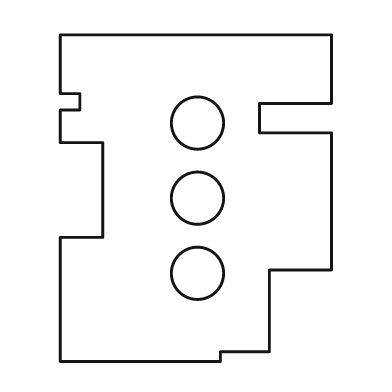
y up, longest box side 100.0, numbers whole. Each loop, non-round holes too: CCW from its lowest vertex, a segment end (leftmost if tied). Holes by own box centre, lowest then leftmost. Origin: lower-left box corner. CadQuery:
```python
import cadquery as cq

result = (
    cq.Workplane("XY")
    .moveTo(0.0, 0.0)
    .lineTo(49.0, 0.0)
    .lineTo(49.0, 3.0)
    .lineTo(64.0, 3.0)
    .lineTo(64.0, 28.0)
    .lineTo(83.0, 28.0)
    .lineTo(83.0, 70.0)
    .lineTo(61.0, 70.0)
    .lineTo(61.0, 79.0)
    .lineTo(83.0, 79.0)
    .lineTo(83.0, 100.0)
    .lineTo(0.0, 100.0)
    .lineTo(0.0, 82.0)
    .lineTo(6.0, 82.0)
    .lineTo(6.0, 77.0)
    .lineTo(0.0, 77.0)
    .lineTo(0.0, 67.0)
    .lineTo(13.0, 67.0)
    .lineTo(13.0, 38.0)
    .lineTo(0.0, 38.0)
    .close()
    .moveTo(42.0, 27.0)
    .circle(8.0)
    .moveTo(42.0, 50.0)
    .circle(8.0)
    .moveTo(42.0, 73.0)
    .circle(8.0)
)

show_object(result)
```